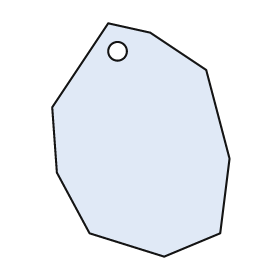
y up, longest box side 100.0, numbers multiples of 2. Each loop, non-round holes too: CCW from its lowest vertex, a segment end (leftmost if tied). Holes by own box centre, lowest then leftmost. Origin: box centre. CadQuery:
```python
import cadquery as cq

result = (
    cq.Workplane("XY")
    .moveTo(10.0, -50.0)
    .lineTo(34.0, -40.0)
    .lineTo(38.0, -8.0)
    .lineTo(28.0, 30.0)
    .lineTo(4.0, 46.0)
    .lineTo(-14.0, 50.0)
    .lineTo(-38.0, 14.0)
    .lineTo(-36.0, -14.0)
    .lineTo(-22.0, -40.0)
    .close()
    .moveTo(-10.0, 38.0)
    .circle(4.0)
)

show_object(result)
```